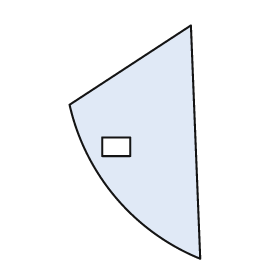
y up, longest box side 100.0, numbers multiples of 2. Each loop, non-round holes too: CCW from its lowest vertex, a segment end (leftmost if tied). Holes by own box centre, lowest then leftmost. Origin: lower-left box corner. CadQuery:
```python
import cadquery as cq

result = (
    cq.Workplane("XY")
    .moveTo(56.0, 0.0)
    .lineTo(52.0, 100.0)
    .lineTo(0.0, 66.0)
    .threePointArc((20.0, 26.0), (56.0, 0.0))
    .close()
    .moveTo(14.0, 44.0)
    .lineTo(26.0, 44.0)
    .lineTo(26.0, 52.0)
    .lineTo(14.0, 52.0)
    .close()
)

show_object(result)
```